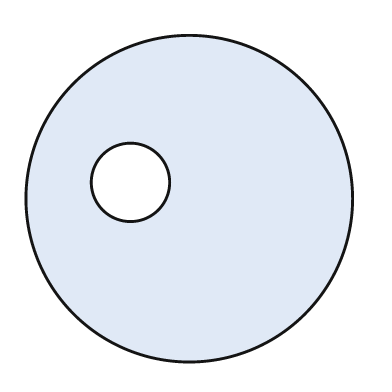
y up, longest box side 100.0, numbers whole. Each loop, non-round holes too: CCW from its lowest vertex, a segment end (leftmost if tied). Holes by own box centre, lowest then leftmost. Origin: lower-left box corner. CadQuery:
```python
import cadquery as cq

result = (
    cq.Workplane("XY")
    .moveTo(50.0, 50.0)
    .circle(50.0)
    .moveTo(32.0, 55.0)
    .circle(12.0)
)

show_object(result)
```